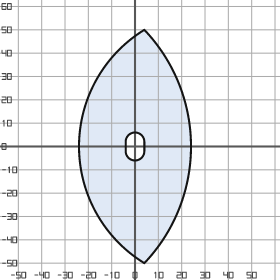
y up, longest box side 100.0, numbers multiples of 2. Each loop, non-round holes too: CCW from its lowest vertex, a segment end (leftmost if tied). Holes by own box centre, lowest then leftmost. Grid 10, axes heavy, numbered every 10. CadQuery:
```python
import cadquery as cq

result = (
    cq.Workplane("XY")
    .moveTo(4.0, -50.0)
    .threePointArc((24.0, 0.0), (4.0, 50.0))
    .threePointArc((-24.0, 0.0), (4.0, -50.0))
    .close()
    .moveTo(-4.0, -2.0)
    .threePointArc((0.0, -6.0), (4.0, -2.0))
    .lineTo(4.0, 2.0)
    .threePointArc((0.0, 6.0), (-4.0, 2.0))
    .close()
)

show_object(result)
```